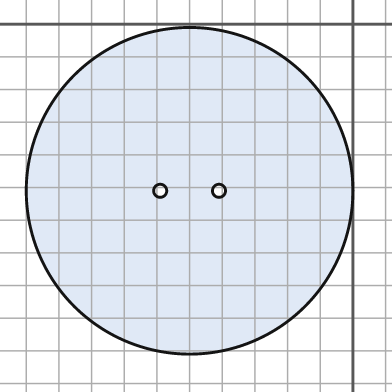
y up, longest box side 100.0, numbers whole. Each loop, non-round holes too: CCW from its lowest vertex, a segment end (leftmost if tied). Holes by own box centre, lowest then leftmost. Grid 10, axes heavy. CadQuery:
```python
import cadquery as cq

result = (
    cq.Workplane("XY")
    .moveTo(-50.0, -51.0)
    .circle(50.0)
    .moveTo(-59.0, -51.0)
    .circle(2.0)
    .moveTo(-41.0, -51.0)
    .circle(2.0)
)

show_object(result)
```